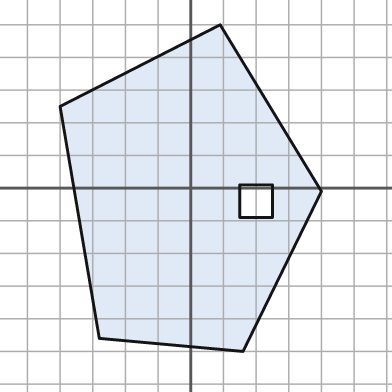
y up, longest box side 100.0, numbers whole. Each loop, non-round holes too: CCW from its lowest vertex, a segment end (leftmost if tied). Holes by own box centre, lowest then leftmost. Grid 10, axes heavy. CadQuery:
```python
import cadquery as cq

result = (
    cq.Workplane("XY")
    .moveTo(16.0, -50.0)
    .lineTo(40.0, -1.0)
    .lineTo(9.0, 50.0)
    .lineTo(-40.0, 25.0)
    .lineTo(-28.0, -46.0)
    .close()
    .moveTo(15.0, -9.0)
    .lineTo(25.0, -9.0)
    .lineTo(25.0, 1.0)
    .lineTo(15.0, 1.0)
    .close()
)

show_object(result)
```